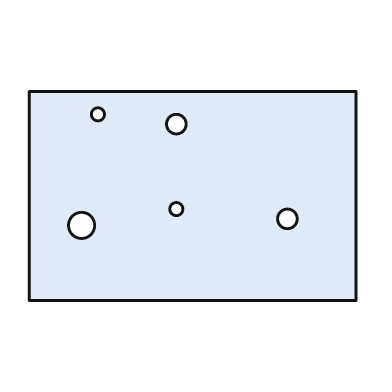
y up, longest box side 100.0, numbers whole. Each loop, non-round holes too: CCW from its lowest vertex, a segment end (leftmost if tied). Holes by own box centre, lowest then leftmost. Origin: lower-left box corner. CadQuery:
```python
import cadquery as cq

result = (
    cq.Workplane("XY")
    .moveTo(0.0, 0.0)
    .lineTo(100.0, 0.0)
    .lineTo(100.0, 64.0)
    .lineTo(0.0, 64.0)
    .close()
    .moveTo(16.0, 23.0)
    .circle(4.0)
    .moveTo(79.0, 25.0)
    .circle(3.0)
    .moveTo(45.0, 28.0)
    .circle(2.0)
    .moveTo(45.0, 54.0)
    .circle(3.0)
    .moveTo(21.0, 57.0)
    .circle(2.0)
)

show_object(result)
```